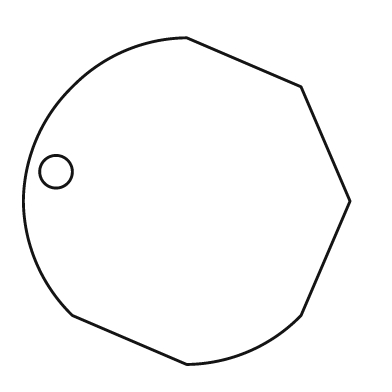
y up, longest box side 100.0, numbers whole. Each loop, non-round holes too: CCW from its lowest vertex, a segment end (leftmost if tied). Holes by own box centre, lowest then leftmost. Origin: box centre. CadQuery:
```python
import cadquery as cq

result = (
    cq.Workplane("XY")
    .moveTo(0.0, -50.0)
    .threePointArc((19.0, -46.0), (35.0, -35.0))
    .lineTo(50.0, 0.0)
    .lineTo(35.0, 35.0)
    .lineTo(0.0, 50.0)
    .threePointArc((-19.0, 46.0), (-35.0, 35.0))
    .threePointArc((-46.0, 19.0), (-50.0, 0.0))
    .threePointArc((-46.0, -19.0), (-35.0, -35.0))
    .close()
    .moveTo(-40.0, 9.0)
    .circle(5.0)
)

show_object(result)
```